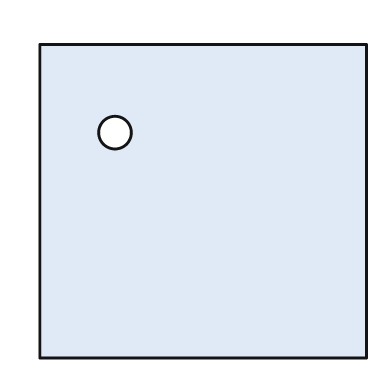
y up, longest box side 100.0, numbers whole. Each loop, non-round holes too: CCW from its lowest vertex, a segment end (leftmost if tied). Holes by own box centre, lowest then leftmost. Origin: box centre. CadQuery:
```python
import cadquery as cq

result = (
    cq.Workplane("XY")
    .moveTo(-50.0, -48.0)
    .lineTo(50.0, -48.0)
    .lineTo(50.0, 48.0)
    .lineTo(-50.0, 48.0)
    .close()
    .moveTo(-27.0, 21.0)
    .circle(5.0)
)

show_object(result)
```